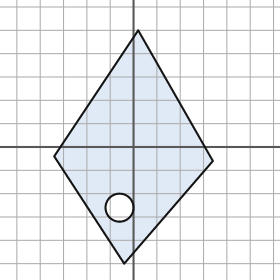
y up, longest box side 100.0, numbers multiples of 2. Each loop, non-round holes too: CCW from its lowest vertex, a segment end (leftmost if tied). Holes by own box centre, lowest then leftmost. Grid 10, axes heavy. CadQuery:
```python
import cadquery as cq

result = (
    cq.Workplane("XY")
    .moveTo(-4.0, -50.0)
    .lineTo(34.0, -6.0)
    .lineTo(2.0, 50.0)
    .lineTo(-34.0, -4.0)
    .close()
    .moveTo(-6.0, -26.0)
    .circle(6.0)
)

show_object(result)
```